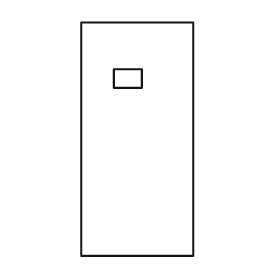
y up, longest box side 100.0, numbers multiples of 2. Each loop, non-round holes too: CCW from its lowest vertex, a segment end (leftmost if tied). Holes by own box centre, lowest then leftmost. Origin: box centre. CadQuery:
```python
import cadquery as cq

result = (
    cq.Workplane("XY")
    .moveTo(-24.0, -50.0)
    .lineTo(24.0, -50.0)
    .lineTo(24.0, 50.0)
    .lineTo(-24.0, 50.0)
    .close()
    .moveTo(-10.0, 22.0)
    .lineTo(2.0, 22.0)
    .lineTo(2.0, 30.0)
    .lineTo(-10.0, 30.0)
    .close()
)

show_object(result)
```